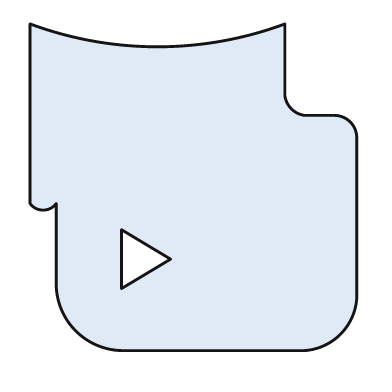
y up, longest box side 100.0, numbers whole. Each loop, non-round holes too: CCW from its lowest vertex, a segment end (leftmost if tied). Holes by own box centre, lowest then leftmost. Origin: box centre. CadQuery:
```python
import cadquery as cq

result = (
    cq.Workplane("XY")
    .moveTo(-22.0, -50.0)
    .lineTo(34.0, -50.0)
    .threePointArc((45.0, -45.0), (50.0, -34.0))
    .lineTo(50.0, 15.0)
    .threePointArc((48.0, 20.0), (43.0, 22.0))
    .lineTo(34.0, 22.0)
    .threePointArc((30.0, 24.0), (28.0, 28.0))
    .lineTo(28.0, 50.0)
    .threePointArc((-11.0, 43.0), (-50.0, 50.0))
    .lineTo(-50.0, -5.0)
    .threePointArc((-46.0, -7.0), (-42.0, -5.0))
    .lineTo(-42.0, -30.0)
    .threePointArc((-36.0, -44.0), (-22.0, -50.0))
    .close()
    .moveTo(-22.0, -31.0)
    .lineTo(-7.0, -22.0)
    .lineTo(-22.0, -13.0)
    .close()
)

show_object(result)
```